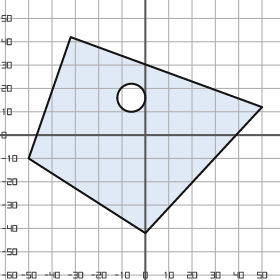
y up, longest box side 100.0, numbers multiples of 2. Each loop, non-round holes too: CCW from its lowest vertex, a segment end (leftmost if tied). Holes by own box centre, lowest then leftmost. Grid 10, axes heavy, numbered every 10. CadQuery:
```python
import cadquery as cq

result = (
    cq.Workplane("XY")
    .moveTo(0.0, -42.0)
    .lineTo(50.0, 12.0)
    .lineTo(-32.0, 42.0)
    .lineTo(-50.0, -10.0)
    .close()
    .moveTo(-6.0, 16.0)
    .circle(6.0)
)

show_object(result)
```